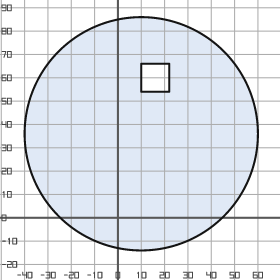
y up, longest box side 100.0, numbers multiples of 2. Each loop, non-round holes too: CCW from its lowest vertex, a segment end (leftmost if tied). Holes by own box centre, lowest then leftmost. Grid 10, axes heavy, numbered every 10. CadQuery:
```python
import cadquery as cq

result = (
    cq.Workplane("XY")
    .moveTo(10.0, 36.0)
    .circle(50.0)
    .moveTo(10.0, 54.0)
    .lineTo(22.0, 54.0)
    .lineTo(22.0, 66.0)
    .lineTo(10.0, 66.0)
    .close()
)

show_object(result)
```